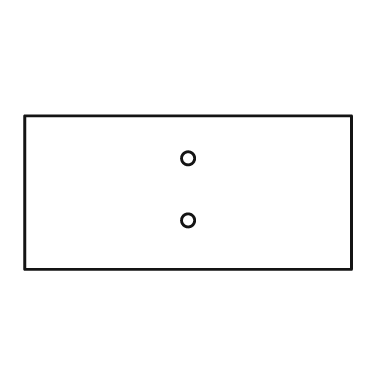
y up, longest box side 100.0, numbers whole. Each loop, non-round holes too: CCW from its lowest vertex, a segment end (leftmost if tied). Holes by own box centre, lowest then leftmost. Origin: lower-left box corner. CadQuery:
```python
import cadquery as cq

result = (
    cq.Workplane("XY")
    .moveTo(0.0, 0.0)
    .lineTo(100.0, 0.0)
    .lineTo(100.0, 47.0)
    .lineTo(0.0, 47.0)
    .close()
    .moveTo(50.0, 15.0)
    .circle(2.0)
    .moveTo(50.0, 34.0)
    .circle(2.0)
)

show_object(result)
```